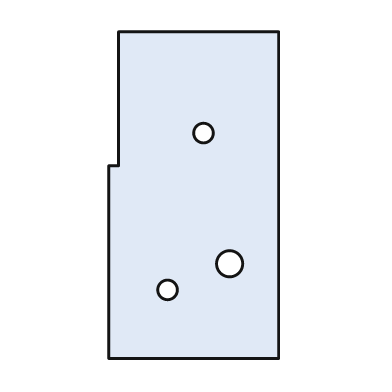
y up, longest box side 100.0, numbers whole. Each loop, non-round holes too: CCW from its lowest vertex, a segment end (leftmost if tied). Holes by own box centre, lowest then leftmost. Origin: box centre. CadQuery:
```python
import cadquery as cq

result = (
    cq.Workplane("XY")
    .moveTo(-26.0, -50.0)
    .lineTo(26.0, -50.0)
    .lineTo(26.0, 50.0)
    .lineTo(-23.0, 50.0)
    .lineTo(-23.0, 9.0)
    .lineTo(-26.0, 9.0)
    .close()
    .moveTo(-8.0, -29.0)
    .circle(3.0)
    .moveTo(11.0, -21.0)
    .circle(4.0)
    .moveTo(3.0, 19.0)
    .circle(3.0)
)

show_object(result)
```